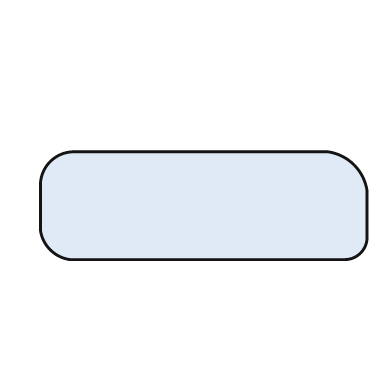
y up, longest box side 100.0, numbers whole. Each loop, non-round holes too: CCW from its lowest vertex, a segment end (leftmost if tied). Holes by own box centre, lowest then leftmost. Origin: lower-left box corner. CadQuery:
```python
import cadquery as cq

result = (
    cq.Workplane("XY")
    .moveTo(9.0, 0.0)
    .lineTo(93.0, 0.0)
    .threePointArc((98.0, 2.0), (100.0, 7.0))
    .lineTo(100.0, 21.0)
    .threePointArc((96.0, 29.0), (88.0, 33.0))
    .lineTo(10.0, 33.0)
    .threePointArc((3.0, 30.0), (0.0, 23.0))
    .lineTo(0.0, 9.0)
    .threePointArc((3.0, 3.0), (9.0, 0.0))
    .close()
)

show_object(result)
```